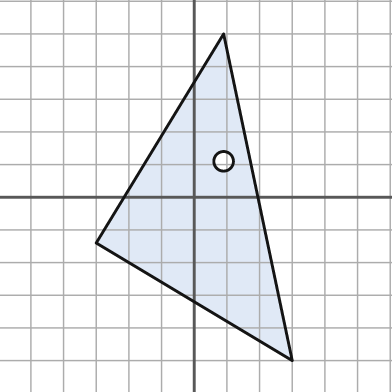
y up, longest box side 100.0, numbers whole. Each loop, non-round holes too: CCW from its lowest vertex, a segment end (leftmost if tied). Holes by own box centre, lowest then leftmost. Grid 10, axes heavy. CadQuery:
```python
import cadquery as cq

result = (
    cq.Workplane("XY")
    .moveTo(30.0, -50.0)
    .lineTo(9.0, 50.0)
    .lineTo(-30.0, -14.0)
    .close()
    .moveTo(9.0, 11.0)
    .circle(3.0)
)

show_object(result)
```